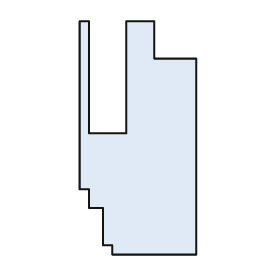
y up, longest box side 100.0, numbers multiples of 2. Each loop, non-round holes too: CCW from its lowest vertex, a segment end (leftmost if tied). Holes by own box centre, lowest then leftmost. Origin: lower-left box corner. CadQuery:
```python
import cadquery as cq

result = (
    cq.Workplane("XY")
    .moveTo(14.0, 0.0)
    .lineTo(50.0, 0.0)
    .lineTo(50.0, 84.0)
    .lineTo(32.0, 84.0)
    .lineTo(32.0, 100.0)
    .lineTo(20.0, 100.0)
    .lineTo(20.0, 52.0)
    .lineTo(4.0, 52.0)
    .lineTo(4.0, 100.0)
    .lineTo(0.0, 100.0)
    .lineTo(0.0, 28.0)
    .lineTo(4.0, 28.0)
    .lineTo(4.0, 20.0)
    .lineTo(10.0, 20.0)
    .lineTo(10.0, 4.0)
    .lineTo(14.0, 4.0)
    .close()
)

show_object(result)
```